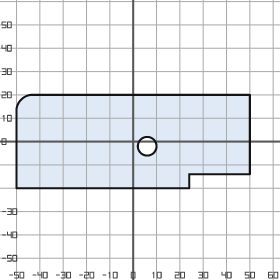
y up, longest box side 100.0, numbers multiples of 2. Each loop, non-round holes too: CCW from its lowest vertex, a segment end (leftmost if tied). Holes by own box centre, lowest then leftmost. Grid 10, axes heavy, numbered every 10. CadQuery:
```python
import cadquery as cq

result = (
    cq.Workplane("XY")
    .moveTo(-50.0, -20.0)
    .lineTo(24.0, -20.0)
    .lineTo(24.0, -14.0)
    .lineTo(50.0, -14.0)
    .lineTo(50.0, 20.0)
    .lineTo(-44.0, 20.0)
    .threePointArc((-48.0, 18.0), (-50.0, 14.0))
    .close()
    .moveTo(6.0, -2.0)
    .circle(4.0)
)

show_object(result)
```